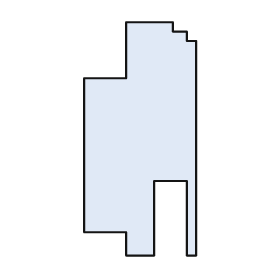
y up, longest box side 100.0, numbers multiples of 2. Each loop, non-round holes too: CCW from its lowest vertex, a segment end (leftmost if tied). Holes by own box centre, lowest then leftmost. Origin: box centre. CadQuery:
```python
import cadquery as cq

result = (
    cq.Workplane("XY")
    .moveTo(-6.0, -50.0)
    .lineTo(6.0, -50.0)
    .lineTo(6.0, -18.0)
    .lineTo(20.0, -18.0)
    .lineTo(20.0, -50.0)
    .lineTo(24.0, -50.0)
    .lineTo(24.0, 42.0)
    .lineTo(20.0, 42.0)
    .lineTo(20.0, 46.0)
    .lineTo(14.0, 46.0)
    .lineTo(14.0, 50.0)
    .lineTo(-6.0, 50.0)
    .lineTo(-6.0, 26.0)
    .lineTo(-24.0, 26.0)
    .lineTo(-24.0, -40.0)
    .lineTo(-6.0, -40.0)
    .close()
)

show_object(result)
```